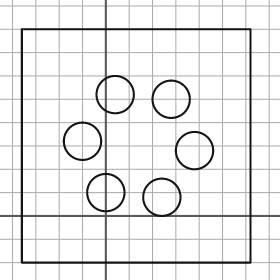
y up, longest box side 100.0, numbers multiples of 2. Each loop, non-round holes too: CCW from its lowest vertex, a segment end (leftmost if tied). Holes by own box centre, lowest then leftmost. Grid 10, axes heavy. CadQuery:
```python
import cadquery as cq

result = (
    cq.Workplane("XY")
    .moveTo(-36.0, -20.0)
    .lineTo(62.0, -20.0)
    .lineTo(62.0, 80.0)
    .lineTo(-36.0, 80.0)
    .close()
    .moveTo(24.0, 8.0)
    .circle(8.0)
    .moveTo(0.0, 10.0)
    .circle(8.0)
    .moveTo(38.0, 28.0)
    .circle(8.0)
    .moveTo(-10.0, 32.0)
    .circle(8.0)
    .moveTo(28.0, 50.0)
    .circle(8.0)
    .moveTo(4.0, 52.0)
    .circle(8.0)
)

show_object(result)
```